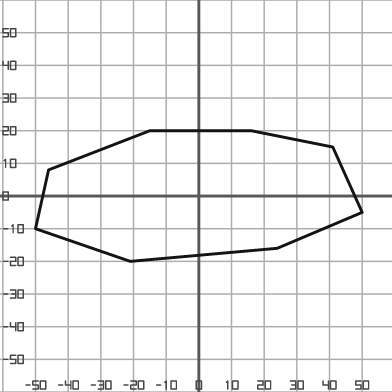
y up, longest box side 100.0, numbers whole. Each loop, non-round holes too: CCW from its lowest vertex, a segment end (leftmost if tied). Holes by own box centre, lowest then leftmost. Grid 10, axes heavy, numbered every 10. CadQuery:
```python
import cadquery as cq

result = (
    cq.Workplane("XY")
    .moveTo(-21.0, -20.0)
    .lineTo(24.0, -16.0)
    .lineTo(50.0, -5.0)
    .lineTo(41.0, 15.0)
    .lineTo(16.0, 20.0)
    .lineTo(-15.0, 20.0)
    .lineTo(-46.0, 8.0)
    .lineTo(-50.0, -10.0)
    .close()
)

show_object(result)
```